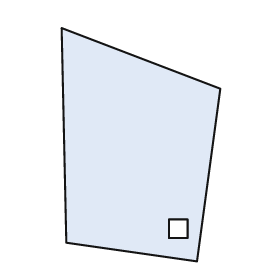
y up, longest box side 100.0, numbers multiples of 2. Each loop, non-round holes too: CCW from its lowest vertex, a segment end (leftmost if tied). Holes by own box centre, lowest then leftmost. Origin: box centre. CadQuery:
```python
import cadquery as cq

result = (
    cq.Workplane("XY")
    .moveTo(24.0, -50.0)
    .lineTo(34.0, 24.0)
    .lineTo(-34.0, 50.0)
    .lineTo(-32.0, -42.0)
    .close()
    .moveTo(12.0, -40.0)
    .lineTo(20.0, -40.0)
    .lineTo(20.0, -32.0)
    .lineTo(12.0, -32.0)
    .close()
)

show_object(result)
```